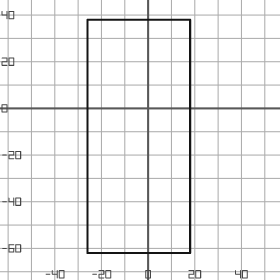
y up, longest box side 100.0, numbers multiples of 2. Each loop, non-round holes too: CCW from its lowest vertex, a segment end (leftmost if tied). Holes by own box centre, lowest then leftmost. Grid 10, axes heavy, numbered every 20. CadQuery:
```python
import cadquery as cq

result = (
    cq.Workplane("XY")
    .moveTo(-26.0, -62.0)
    .lineTo(18.0, -62.0)
    .lineTo(18.0, 38.0)
    .lineTo(-26.0, 38.0)
    .close()
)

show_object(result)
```